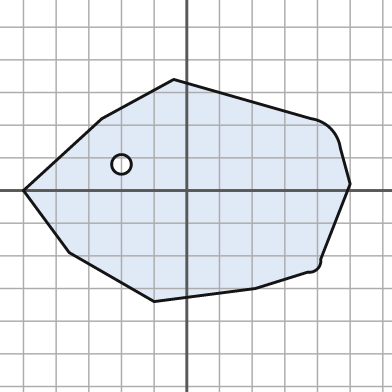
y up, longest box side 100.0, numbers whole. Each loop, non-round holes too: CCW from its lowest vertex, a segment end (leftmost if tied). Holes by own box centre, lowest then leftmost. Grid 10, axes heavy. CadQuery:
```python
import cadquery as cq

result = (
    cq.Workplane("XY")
    .moveTo(-10.0, -34.0)
    .lineTo(21.0, -30.0)
    .lineTo(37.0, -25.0)
    .threePointArc((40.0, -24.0), (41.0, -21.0))
    .lineTo(50.0, 2.0)
    .lineTo(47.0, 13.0)
    .threePointArc((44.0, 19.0), (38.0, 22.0))
    .lineTo(-4.0, 34.0)
    .lineTo(-26.0, 22.0)
    .lineTo(-50.0, 0.0)
    .lineTo(-36.0, -19.0)
    .close()
    .moveTo(-20.0, 8.0)
    .circle(3.0)
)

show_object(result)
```